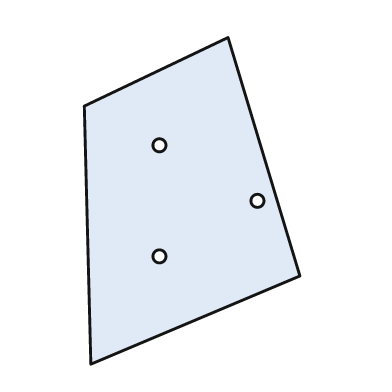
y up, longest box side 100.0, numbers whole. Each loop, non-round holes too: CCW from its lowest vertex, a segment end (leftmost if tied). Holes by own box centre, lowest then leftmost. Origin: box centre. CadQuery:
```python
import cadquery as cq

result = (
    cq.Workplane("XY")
    .moveTo(-31.0, -50.0)
    .lineTo(33.0, -23.0)
    .lineTo(11.0, 50.0)
    .lineTo(-33.0, 29.0)
    .close()
    .moveTo(-10.0, -17.0)
    .circle(2.0)
    .moveTo(20.0, 0.0)
    .circle(2.0)
    .moveTo(-10.0, 17.0)
    .circle(2.0)
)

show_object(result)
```